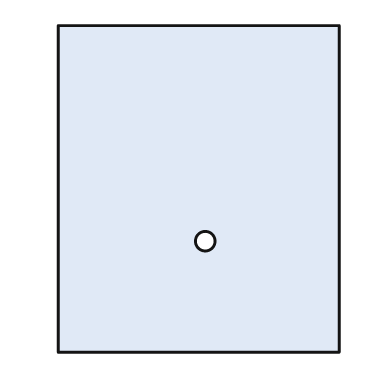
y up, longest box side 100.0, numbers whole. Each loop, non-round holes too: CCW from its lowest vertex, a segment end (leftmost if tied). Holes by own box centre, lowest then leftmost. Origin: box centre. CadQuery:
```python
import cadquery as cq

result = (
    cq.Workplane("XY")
    .moveTo(-43.0, -50.0)
    .lineTo(43.0, -50.0)
    .lineTo(43.0, 50.0)
    .lineTo(-43.0, 50.0)
    .close()
    .moveTo(2.0, -16.0)
    .circle(3.0)
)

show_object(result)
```